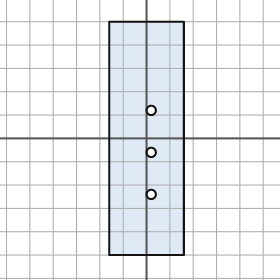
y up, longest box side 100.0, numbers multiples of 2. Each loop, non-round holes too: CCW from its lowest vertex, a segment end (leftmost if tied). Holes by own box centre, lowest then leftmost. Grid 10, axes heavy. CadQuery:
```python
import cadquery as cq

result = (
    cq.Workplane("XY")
    .moveTo(-16.0, -50.0)
    .lineTo(16.0, -50.0)
    .lineTo(16.0, 50.0)
    .lineTo(-16.0, 50.0)
    .close()
    .moveTo(2.0, -24.0)
    .circle(2.0)
    .moveTo(2.0, -6.0)
    .circle(2.0)
    .moveTo(2.0, 12.0)
    .circle(2.0)
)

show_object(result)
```